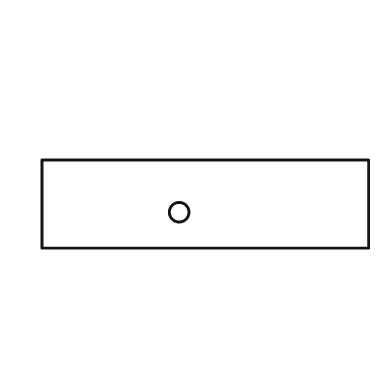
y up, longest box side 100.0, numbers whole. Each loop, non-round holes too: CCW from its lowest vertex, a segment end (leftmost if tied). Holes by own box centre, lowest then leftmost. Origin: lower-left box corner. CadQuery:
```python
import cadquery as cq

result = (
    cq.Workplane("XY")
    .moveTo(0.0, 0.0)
    .lineTo(100.0, 0.0)
    .lineTo(100.0, 27.0)
    .lineTo(0.0, 27.0)
    .close()
    .moveTo(42.0, 11.0)
    .circle(3.0)
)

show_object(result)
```